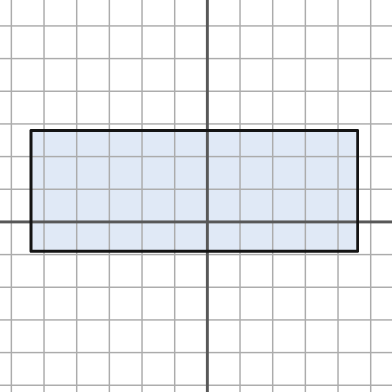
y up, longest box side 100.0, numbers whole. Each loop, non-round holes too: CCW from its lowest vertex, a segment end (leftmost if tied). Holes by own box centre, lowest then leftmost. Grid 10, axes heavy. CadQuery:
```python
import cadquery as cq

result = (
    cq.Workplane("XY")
    .moveTo(-54.0, -9.0)
    .lineTo(46.0, -9.0)
    .lineTo(46.0, 28.0)
    .lineTo(-54.0, 28.0)
    .close()
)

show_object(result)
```